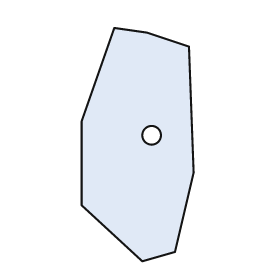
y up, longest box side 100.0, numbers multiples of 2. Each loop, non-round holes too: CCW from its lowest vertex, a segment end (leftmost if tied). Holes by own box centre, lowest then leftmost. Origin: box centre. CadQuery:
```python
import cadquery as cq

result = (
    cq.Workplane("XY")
    .moveTo(2.0, -50.0)
    .lineTo(16.0, -46.0)
    .lineTo(24.0, -12.0)
    .lineTo(22.0, 42.0)
    .lineTo(4.0, 48.0)
    .lineTo(-10.0, 50.0)
    .lineTo(-24.0, 10.0)
    .lineTo(-24.0, -26.0)
    .close()
    .moveTo(6.0, 4.0)
    .circle(4.0)
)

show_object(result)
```